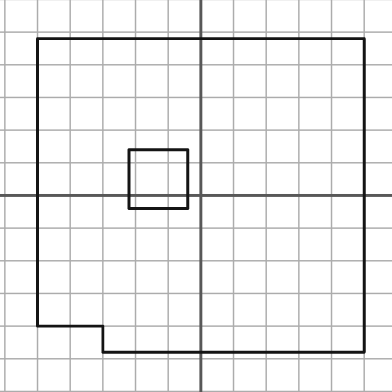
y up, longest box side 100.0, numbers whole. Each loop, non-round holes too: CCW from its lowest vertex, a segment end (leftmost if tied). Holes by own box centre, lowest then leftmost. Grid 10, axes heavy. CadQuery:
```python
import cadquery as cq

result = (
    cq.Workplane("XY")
    .moveTo(-30.0, -48.0)
    .lineTo(50.0, -48.0)
    .lineTo(50.0, 48.0)
    .lineTo(-50.0, 48.0)
    .lineTo(-50.0, -40.0)
    .lineTo(-30.0, -40.0)
    .close()
    .moveTo(-22.0, -4.0)
    .lineTo(-4.0, -4.0)
    .lineTo(-4.0, 14.0)
    .lineTo(-22.0, 14.0)
    .close()
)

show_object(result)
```